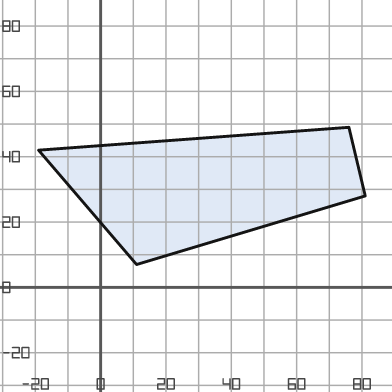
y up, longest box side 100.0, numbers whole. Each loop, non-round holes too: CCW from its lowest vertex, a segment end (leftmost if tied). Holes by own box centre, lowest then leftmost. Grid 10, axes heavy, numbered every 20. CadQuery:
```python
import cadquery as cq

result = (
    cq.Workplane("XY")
    .moveTo(11.0, 7.0)
    .lineTo(81.0, 28.0)
    .lineTo(76.0, 49.0)
    .lineTo(-19.0, 42.0)
    .close()
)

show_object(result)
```